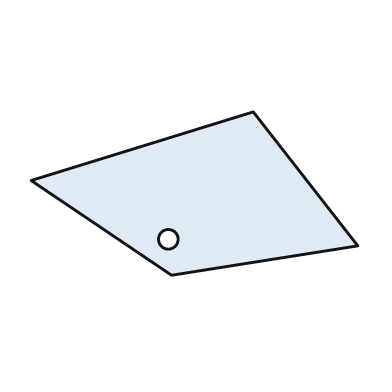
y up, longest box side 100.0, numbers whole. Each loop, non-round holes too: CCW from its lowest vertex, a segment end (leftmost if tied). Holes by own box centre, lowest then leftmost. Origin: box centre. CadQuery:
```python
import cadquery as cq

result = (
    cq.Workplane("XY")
    .moveTo(-7.0, -25.0)
    .lineTo(50.0, -16.0)
    .lineTo(18.0, 25.0)
    .lineTo(-50.0, 4.0)
    .close()
    .moveTo(-8.0, -14.0)
    .circle(3.0)
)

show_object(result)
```